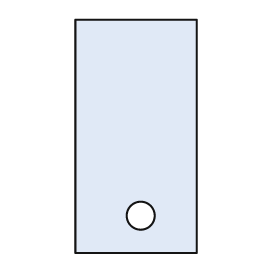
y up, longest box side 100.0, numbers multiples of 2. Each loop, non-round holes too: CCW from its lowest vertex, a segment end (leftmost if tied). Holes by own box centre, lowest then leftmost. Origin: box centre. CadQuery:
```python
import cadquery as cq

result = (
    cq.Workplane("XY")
    .moveTo(-26.0, -50.0)
    .lineTo(26.0, -50.0)
    .lineTo(26.0, 50.0)
    .lineTo(-26.0, 50.0)
    .close()
    .moveTo(2.0, -34.0)
    .circle(6.0)
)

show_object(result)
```